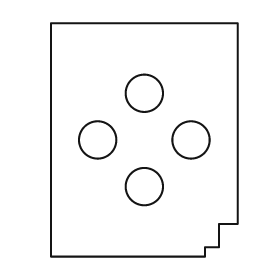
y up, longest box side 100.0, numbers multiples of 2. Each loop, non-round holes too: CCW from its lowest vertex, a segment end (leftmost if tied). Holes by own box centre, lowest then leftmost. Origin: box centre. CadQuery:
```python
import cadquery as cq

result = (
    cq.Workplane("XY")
    .moveTo(-40.0, -50.0)
    .lineTo(26.0, -50.0)
    .lineTo(26.0, -46.0)
    .lineTo(32.0, -46.0)
    .lineTo(32.0, -36.0)
    .lineTo(40.0, -36.0)
    .lineTo(40.0, 50.0)
    .lineTo(-40.0, 50.0)
    .close()
    .moveTo(0.0, -20.0)
    .circle(8.0)
    .moveTo(-20.0, 0.0)
    .circle(8.0)
    .moveTo(20.0, 0.0)
    .circle(8.0)
    .moveTo(0.0, 20.0)
    .circle(8.0)
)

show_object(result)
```